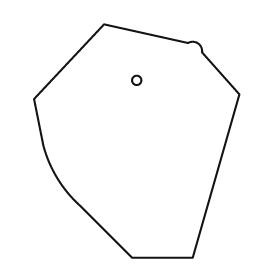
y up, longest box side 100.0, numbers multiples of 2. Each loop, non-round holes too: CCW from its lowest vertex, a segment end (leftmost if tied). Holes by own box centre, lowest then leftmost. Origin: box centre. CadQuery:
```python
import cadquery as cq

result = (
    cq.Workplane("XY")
    .moveTo(-2.0, -50.0)
    .lineTo(24.0, -50.0)
    .lineTo(44.0, 20.0)
    .lineTo(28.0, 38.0)
    .threePointArc((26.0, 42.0), (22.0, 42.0))
    .lineTo(-14.0, 50.0)
    .lineTo(-44.0, 18.0)
    .lineTo(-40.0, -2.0)
    .threePointArc((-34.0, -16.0), (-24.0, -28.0))
    .close()
    .moveTo(0.0, 26.0)
    .circle(2.0)
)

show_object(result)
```